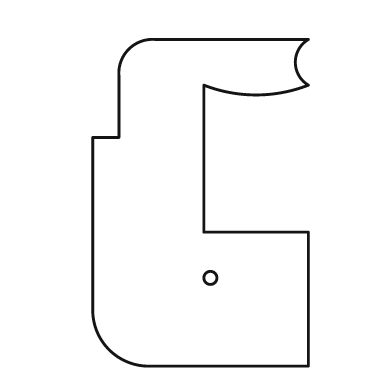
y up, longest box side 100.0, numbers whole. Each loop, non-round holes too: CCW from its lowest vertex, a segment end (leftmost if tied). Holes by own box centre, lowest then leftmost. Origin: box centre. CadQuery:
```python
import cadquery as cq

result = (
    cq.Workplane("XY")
    .moveTo(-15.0, -50.0)
    .lineTo(33.0, -50.0)
    .lineTo(33.0, -9.0)
    .lineTo(1.0, -9.0)
    .lineTo(1.0, 36.0)
    .threePointArc((17.0, 33.0), (33.0, 36.0))
    .threePointArc((29.0, 43.0), (33.0, 50.0))
    .lineTo(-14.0, 50.0)
    .threePointArc((-22.0, 47.0), (-25.0, 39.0))
    .lineTo(-25.0, 20.0)
    .lineTo(-33.0, 20.0)
    .lineTo(-33.0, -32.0)
    .threePointArc((-28.0, -45.0), (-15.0, -50.0))
    .close()
    .moveTo(3.0, -23.0)
    .circle(2.0)
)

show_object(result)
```